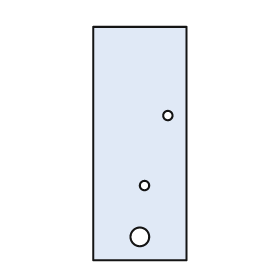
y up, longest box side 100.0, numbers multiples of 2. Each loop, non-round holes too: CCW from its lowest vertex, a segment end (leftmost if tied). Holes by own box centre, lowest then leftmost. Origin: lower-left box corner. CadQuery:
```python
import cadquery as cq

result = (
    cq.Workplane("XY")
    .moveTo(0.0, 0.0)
    .lineTo(40.0, 0.0)
    .lineTo(40.0, 100.0)
    .lineTo(0.0, 100.0)
    .close()
    .moveTo(20.0, 10.0)
    .circle(4.0)
    .moveTo(22.0, 32.0)
    .circle(2.0)
    .moveTo(32.0, 62.0)
    .circle(2.0)
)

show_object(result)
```